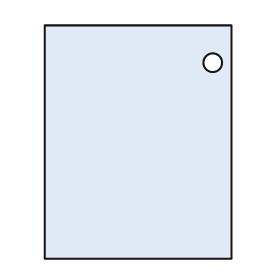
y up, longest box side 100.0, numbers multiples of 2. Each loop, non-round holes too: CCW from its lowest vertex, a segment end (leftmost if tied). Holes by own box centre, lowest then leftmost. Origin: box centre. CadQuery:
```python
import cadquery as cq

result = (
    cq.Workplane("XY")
    .moveTo(-40.0, -50.0)
    .lineTo(40.0, -50.0)
    .lineTo(40.0, 50.0)
    .lineTo(-40.0, 50.0)
    .close()
    .moveTo(32.0, 34.0)
    .circle(4.0)
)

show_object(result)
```